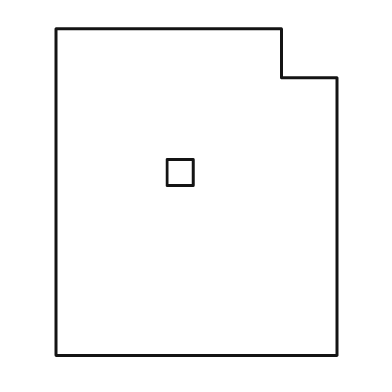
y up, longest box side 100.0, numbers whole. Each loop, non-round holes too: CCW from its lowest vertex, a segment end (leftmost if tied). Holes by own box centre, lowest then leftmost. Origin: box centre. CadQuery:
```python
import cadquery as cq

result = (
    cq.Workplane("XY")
    .moveTo(-43.0, -50.0)
    .lineTo(43.0, -50.0)
    .lineTo(43.0, 35.0)
    .lineTo(26.0, 35.0)
    .lineTo(26.0, 50.0)
    .lineTo(-43.0, 50.0)
    .close()
    .moveTo(-9.0, 2.0)
    .lineTo(-1.0, 2.0)
    .lineTo(-1.0, 10.0)
    .lineTo(-9.0, 10.0)
    .close()
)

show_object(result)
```